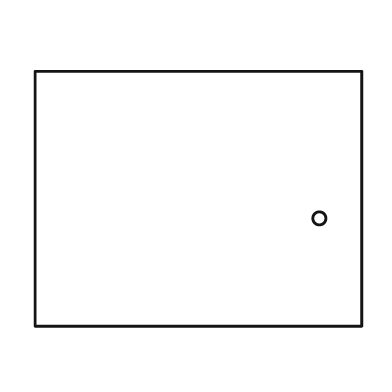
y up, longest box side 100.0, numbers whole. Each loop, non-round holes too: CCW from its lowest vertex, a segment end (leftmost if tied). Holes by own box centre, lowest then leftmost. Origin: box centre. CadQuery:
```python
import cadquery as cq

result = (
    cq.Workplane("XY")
    .moveTo(-50.0, -39.0)
    .lineTo(50.0, -39.0)
    .lineTo(50.0, 39.0)
    .lineTo(-50.0, 39.0)
    .close()
    .moveTo(37.0, -6.0)
    .circle(2.0)
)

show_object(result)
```